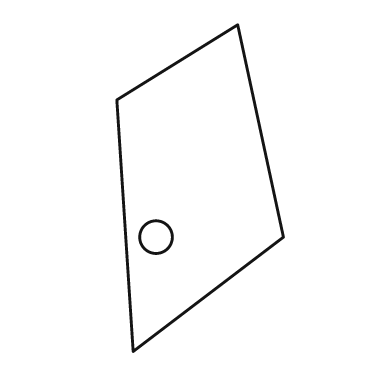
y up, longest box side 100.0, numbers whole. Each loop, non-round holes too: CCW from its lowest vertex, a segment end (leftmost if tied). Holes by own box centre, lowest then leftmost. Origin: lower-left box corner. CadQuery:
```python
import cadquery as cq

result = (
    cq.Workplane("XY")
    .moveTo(5.0, 0.0)
    .lineTo(51.0, 35.0)
    .lineTo(37.0, 100.0)
    .lineTo(0.0, 77.0)
    .close()
    .moveTo(12.0, 35.0)
    .circle(5.0)
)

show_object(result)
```